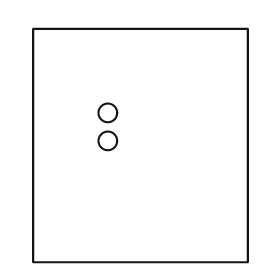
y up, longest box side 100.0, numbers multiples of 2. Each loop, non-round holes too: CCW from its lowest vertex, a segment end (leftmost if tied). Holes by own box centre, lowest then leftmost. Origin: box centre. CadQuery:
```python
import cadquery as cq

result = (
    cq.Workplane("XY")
    .moveTo(-46.0, -50.0)
    .lineTo(46.0, -50.0)
    .lineTo(46.0, 50.0)
    .lineTo(-46.0, 50.0)
    .close()
    .moveTo(-14.0, 2.0)
    .circle(4.0)
    .moveTo(-14.0, 14.0)
    .circle(4.0)
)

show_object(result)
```